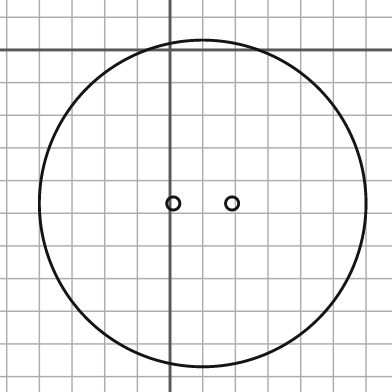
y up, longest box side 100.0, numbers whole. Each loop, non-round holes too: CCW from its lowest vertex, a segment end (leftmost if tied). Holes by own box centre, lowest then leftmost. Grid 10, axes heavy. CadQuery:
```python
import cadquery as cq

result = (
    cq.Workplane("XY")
    .moveTo(10.0, -47.0)
    .circle(50.0)
    .moveTo(1.0, -47.0)
    .circle(2.0)
    .moveTo(19.0, -47.0)
    .circle(2.0)
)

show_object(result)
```